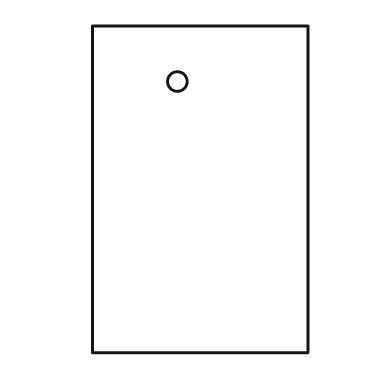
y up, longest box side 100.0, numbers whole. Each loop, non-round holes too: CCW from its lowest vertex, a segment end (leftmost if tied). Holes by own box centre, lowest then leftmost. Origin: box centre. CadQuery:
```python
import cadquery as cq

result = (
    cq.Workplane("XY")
    .moveTo(-33.0, -50.0)
    .lineTo(33.0, -50.0)
    .lineTo(33.0, 50.0)
    .lineTo(-33.0, 50.0)
    .close()
    .moveTo(-7.0, 33.0)
    .circle(3.0)
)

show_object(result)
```